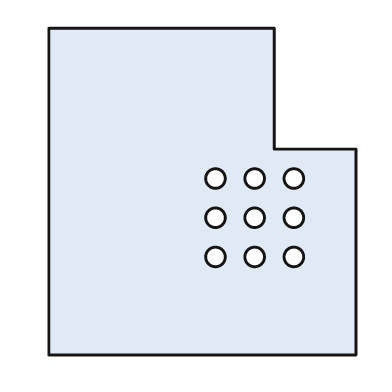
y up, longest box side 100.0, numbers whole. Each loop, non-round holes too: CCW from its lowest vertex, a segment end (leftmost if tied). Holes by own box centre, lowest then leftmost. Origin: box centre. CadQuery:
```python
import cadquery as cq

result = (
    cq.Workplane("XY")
    .moveTo(-47.0, -50.0)
    .lineTo(47.0, -50.0)
    .lineTo(47.0, 13.0)
    .lineTo(22.0, 13.0)
    .lineTo(22.0, 50.0)
    .lineTo(-47.0, 50.0)
    .close()
    .moveTo(4.0, -20.0)
    .circle(3.0)
    .moveTo(16.0, -20.0)
    .circle(3.0)
    .moveTo(28.0, -20.0)
    .circle(3.0)
    .moveTo(4.0, -8.0)
    .circle(3.0)
    .moveTo(16.0, -8.0)
    .circle(3.0)
    .moveTo(28.0, -8.0)
    .circle(3.0)
    .moveTo(4.0, 4.0)
    .circle(3.0)
    .moveTo(16.0, 4.0)
    .circle(3.0)
    .moveTo(28.0, 4.0)
    .circle(3.0)
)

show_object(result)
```